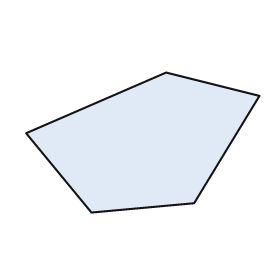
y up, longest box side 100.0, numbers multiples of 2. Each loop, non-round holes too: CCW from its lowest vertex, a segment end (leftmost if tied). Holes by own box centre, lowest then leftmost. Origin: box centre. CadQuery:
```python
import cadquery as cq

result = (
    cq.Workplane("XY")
    .moveTo(-22.0, -30.0)
    .lineTo(22.0, -26.0)
    .lineTo(50.0, 20.0)
    .lineTo(10.0, 30.0)
    .lineTo(-50.0, 4.0)
    .close()
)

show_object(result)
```